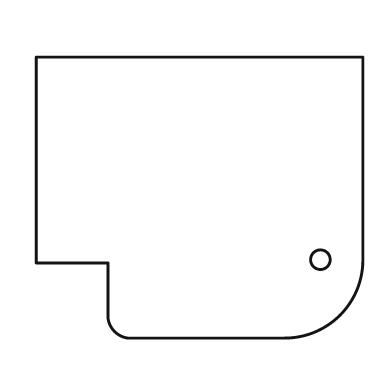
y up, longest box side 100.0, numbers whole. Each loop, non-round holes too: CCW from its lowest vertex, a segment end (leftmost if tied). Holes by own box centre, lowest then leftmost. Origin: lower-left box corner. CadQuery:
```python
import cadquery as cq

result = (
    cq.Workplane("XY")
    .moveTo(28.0, 0.0)
    .lineTo(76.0, 0.0)
    .threePointArc((93.0, 7.0), (100.0, 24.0))
    .lineTo(100.0, 86.0)
    .lineTo(0.0, 86.0)
    .lineTo(0.0, 23.0)
    .lineTo(22.0, 23.0)
    .lineTo(22.0, 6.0)
    .threePointArc((24.0, 2.0), (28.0, 0.0))
    .close()
    .moveTo(87.0, 24.0)
    .circle(3.0)
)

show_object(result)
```